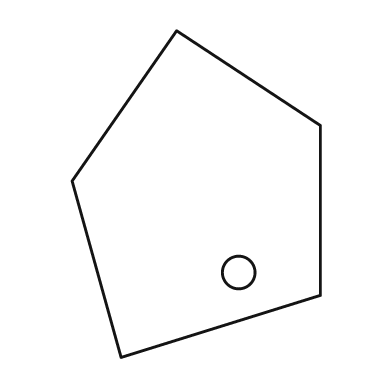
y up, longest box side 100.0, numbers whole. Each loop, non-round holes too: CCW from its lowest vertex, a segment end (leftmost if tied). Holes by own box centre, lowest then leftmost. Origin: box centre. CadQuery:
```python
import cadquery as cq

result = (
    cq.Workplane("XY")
    .moveTo(-23.0, -50.0)
    .lineTo(38.0, -31.0)
    .lineTo(38.0, 21.0)
    .lineTo(-6.0, 50.0)
    .lineTo(-38.0, 4.0)
    .close()
    .moveTo(13.0, -24.0)
    .circle(5.0)
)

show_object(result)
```